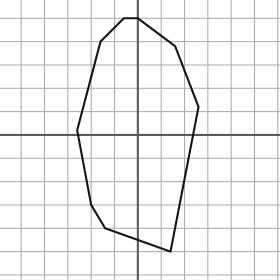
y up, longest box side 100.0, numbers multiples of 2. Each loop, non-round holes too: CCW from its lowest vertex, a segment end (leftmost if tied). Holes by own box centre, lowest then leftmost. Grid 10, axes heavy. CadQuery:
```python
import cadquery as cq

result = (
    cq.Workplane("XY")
    .moveTo(14.0, -50.0)
    .lineTo(26.0, 12.0)
    .lineTo(16.0, 38.0)
    .lineTo(0.0, 50.0)
    .lineTo(-6.0, 50.0)
    .lineTo(-16.0, 40.0)
    .lineTo(-26.0, 2.0)
    .lineTo(-20.0, -30.0)
    .lineTo(-14.0, -40.0)
    .close()
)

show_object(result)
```